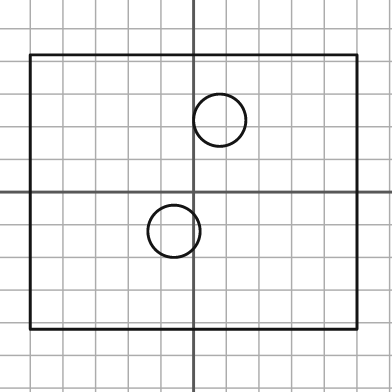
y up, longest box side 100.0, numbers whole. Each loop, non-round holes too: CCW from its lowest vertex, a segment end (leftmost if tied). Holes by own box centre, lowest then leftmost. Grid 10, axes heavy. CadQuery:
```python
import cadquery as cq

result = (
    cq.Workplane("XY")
    .moveTo(-50.0, -42.0)
    .lineTo(50.0, -42.0)
    .lineTo(50.0, 42.0)
    .lineTo(-50.0, 42.0)
    .close()
    .moveTo(-6.0, -12.0)
    .circle(8.0)
    .moveTo(8.0, 22.0)
    .circle(8.0)
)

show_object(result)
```